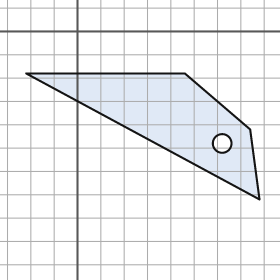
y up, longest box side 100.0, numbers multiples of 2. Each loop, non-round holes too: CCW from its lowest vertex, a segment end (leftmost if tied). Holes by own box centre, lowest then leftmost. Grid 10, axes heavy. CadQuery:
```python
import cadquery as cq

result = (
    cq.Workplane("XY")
    .moveTo(78.0, -72.0)
    .lineTo(74.0, -42.0)
    .lineTo(46.0, -18.0)
    .lineTo(-22.0, -18.0)
    .close()
    .moveTo(62.0, -48.0)
    .circle(4.0)
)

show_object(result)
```